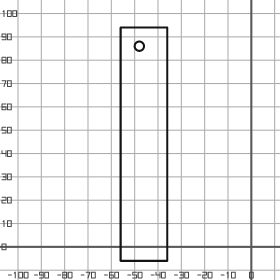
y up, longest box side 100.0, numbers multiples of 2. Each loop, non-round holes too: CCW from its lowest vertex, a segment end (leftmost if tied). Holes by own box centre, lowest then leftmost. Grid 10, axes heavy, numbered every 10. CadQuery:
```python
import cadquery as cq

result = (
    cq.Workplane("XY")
    .moveTo(-56.0, -6.0)
    .lineTo(-36.0, -6.0)
    .lineTo(-36.0, 94.0)
    .lineTo(-56.0, 94.0)
    .close()
    .moveTo(-48.0, 86.0)
    .circle(2.0)
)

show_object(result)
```